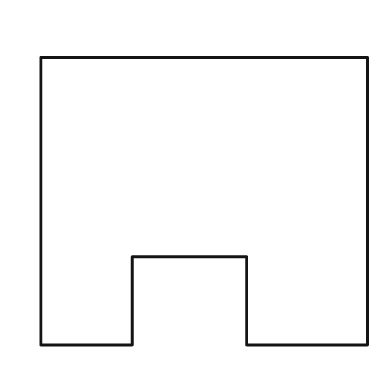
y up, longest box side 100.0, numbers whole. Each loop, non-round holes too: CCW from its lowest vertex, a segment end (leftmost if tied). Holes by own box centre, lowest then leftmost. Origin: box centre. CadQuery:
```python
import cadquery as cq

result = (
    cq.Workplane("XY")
    .moveTo(-50.0, -44.0)
    .lineTo(-22.0, -44.0)
    .lineTo(-22.0, -17.0)
    .lineTo(13.0, -17.0)
    .lineTo(13.0, -44.0)
    .lineTo(50.0, -44.0)
    .lineTo(50.0, 44.0)
    .lineTo(-50.0, 44.0)
    .close()
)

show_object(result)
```